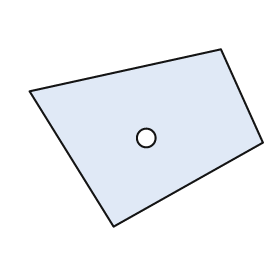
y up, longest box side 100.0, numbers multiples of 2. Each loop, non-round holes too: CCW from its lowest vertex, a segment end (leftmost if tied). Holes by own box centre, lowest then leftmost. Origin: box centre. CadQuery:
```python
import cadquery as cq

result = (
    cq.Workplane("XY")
    .moveTo(-14.0, -38.0)
    .lineTo(50.0, -2.0)
    .lineTo(32.0, 38.0)
    .lineTo(-50.0, 20.0)
    .close()
    .moveTo(0.0, 0.0)
    .circle(4.0)
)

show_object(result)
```